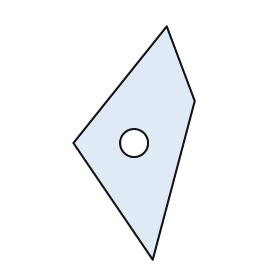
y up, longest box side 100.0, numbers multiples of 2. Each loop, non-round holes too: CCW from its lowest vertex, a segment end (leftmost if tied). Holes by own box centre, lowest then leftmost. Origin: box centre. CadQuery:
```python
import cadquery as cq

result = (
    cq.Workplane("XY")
    .moveTo(8.0, -50.0)
    .lineTo(26.0, 18.0)
    .lineTo(14.0, 50.0)
    .lineTo(-26.0, 0.0)
    .close()
    .moveTo(0.0, 0.0)
    .circle(6.0)
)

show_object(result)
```